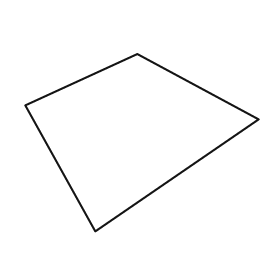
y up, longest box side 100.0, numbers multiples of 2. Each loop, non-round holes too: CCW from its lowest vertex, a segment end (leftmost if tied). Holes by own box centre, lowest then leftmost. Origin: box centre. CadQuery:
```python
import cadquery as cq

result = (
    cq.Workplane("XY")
    .moveTo(-20.0, -38.0)
    .lineTo(50.0, 10.0)
    .lineTo(-2.0, 38.0)
    .lineTo(-50.0, 16.0)
    .close()
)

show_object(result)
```